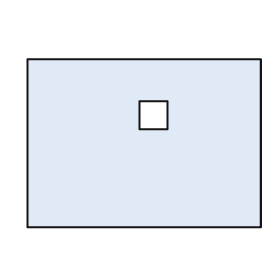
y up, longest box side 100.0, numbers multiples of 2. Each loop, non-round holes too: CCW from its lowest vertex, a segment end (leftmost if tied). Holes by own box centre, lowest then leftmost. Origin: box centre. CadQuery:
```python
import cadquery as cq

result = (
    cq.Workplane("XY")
    .moveTo(-50.0, -36.0)
    .lineTo(50.0, -36.0)
    .lineTo(50.0, 36.0)
    .lineTo(-50.0, 36.0)
    .close()
    .moveTo(-2.0, 6.0)
    .lineTo(10.0, 6.0)
    .lineTo(10.0, 18.0)
    .lineTo(-2.0, 18.0)
    .close()
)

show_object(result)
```